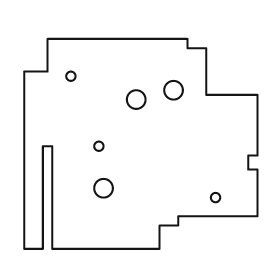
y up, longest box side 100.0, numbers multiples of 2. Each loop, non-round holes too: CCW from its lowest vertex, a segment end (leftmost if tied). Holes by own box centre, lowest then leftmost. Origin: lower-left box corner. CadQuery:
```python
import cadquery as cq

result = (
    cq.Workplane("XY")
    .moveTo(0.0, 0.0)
    .lineTo(8.0, 0.0)
    .lineTo(8.0, 44.0)
    .lineTo(12.0, 44.0)
    .lineTo(12.0, 0.0)
    .lineTo(58.0, 0.0)
    .lineTo(58.0, 10.0)
    .lineTo(66.0, 10.0)
    .lineTo(66.0, 14.0)
    .lineTo(100.0, 14.0)
    .lineTo(100.0, 34.0)
    .lineTo(96.0, 34.0)
    .lineTo(96.0, 40.0)
    .lineTo(100.0, 40.0)
    .lineTo(100.0, 66.0)
    .lineTo(78.0, 66.0)
    .lineTo(78.0, 86.0)
    .lineTo(70.0, 86.0)
    .lineTo(70.0, 90.0)
    .lineTo(10.0, 90.0)
    .lineTo(10.0, 76.0)
    .lineTo(0.0, 76.0)
    .close()
    .moveTo(82.0, 22.0)
    .circle(2.0)
    .moveTo(34.0, 26.0)
    .circle(4.0)
    .moveTo(32.0, 44.0)
    .circle(2.0)
    .moveTo(48.0, 64.0)
    .circle(4.0)
    .moveTo(64.0, 68.0)
    .circle(4.0)
    .moveTo(20.0, 74.0)
    .circle(2.0)
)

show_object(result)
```